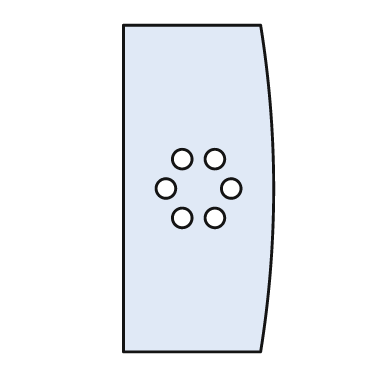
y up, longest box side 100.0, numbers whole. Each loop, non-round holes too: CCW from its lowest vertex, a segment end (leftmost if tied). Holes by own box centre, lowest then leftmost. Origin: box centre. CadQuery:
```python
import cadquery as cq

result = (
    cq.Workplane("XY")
    .moveTo(-23.0, -50.0)
    .lineTo(19.0, -50.0)
    .threePointArc((23.0, 0.0), (19.0, 50.0))
    .lineTo(-23.0, 50.0)
    .close()
    .moveTo(-5.0, -9.0)
    .circle(3.0)
    .moveTo(5.0, -9.0)
    .circle(3.0)
    .moveTo(-10.0, 0.0)
    .circle(3.0)
    .moveTo(10.0, 0.0)
    .circle(3.0)
    .moveTo(-5.0, 9.0)
    .circle(3.0)
    .moveTo(5.0, 9.0)
    .circle(3.0)
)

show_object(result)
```